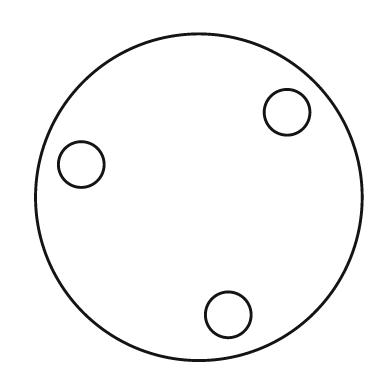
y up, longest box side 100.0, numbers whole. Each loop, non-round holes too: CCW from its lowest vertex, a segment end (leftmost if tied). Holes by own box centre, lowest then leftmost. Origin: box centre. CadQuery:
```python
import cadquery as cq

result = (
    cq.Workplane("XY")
    .moveTo(0.0, 0.0)
    .circle(50.0)
    .moveTo(9.0, -36.0)
    .circle(7.0)
    .moveTo(-36.0, 10.0)
    .circle(7.0)
    .moveTo(27.0, 26.0)
    .circle(7.0)
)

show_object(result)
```